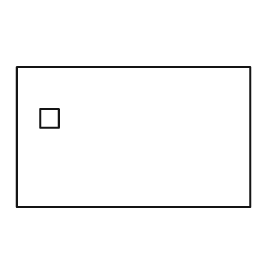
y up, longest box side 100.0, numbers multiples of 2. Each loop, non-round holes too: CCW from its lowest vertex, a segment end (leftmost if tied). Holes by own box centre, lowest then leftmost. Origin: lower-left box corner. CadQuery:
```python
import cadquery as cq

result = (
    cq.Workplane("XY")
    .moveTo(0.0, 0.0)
    .lineTo(100.0, 0.0)
    .lineTo(100.0, 60.0)
    .lineTo(0.0, 60.0)
    .close()
    .moveTo(10.0, 34.0)
    .lineTo(18.0, 34.0)
    .lineTo(18.0, 42.0)
    .lineTo(10.0, 42.0)
    .close()
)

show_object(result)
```